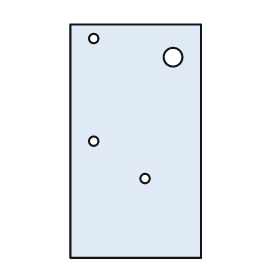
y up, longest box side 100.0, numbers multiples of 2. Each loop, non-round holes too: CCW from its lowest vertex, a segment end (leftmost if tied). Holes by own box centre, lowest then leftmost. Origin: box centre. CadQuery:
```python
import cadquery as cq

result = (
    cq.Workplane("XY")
    .moveTo(-28.0, -50.0)
    .lineTo(28.0, -50.0)
    .lineTo(28.0, 50.0)
    .lineTo(-28.0, 50.0)
    .close()
    .moveTo(4.0, -16.0)
    .circle(2.0)
    .moveTo(-18.0, 0.0)
    .circle(2.0)
    .moveTo(16.0, 36.0)
    .circle(4.0)
    .moveTo(-18.0, 44.0)
    .circle(2.0)
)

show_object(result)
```